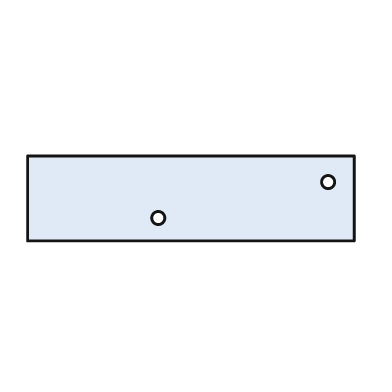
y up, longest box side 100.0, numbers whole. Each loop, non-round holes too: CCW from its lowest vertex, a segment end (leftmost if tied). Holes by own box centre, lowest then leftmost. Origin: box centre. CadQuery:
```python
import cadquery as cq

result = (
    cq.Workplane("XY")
    .moveTo(-50.0, -13.0)
    .lineTo(50.0, -13.0)
    .lineTo(50.0, 13.0)
    .lineTo(-50.0, 13.0)
    .close()
    .moveTo(-10.0, -6.0)
    .circle(2.0)
    .moveTo(42.0, 5.0)
    .circle(2.0)
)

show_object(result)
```